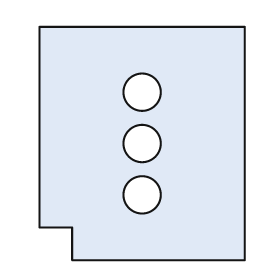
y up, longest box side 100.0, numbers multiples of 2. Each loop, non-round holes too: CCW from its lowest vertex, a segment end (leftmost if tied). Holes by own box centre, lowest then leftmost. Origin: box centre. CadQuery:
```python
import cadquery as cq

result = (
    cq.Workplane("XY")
    .moveTo(-30.0, -50.0)
    .lineTo(44.0, -50.0)
    .lineTo(44.0, 50.0)
    .lineTo(-44.0, 50.0)
    .lineTo(-44.0, -36.0)
    .lineTo(-30.0, -36.0)
    .close()
    .moveTo(0.0, -22.0)
    .circle(8.0)
    .moveTo(0.0, 0.0)
    .circle(8.0)
    .moveTo(0.0, 22.0)
    .circle(8.0)
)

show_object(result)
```